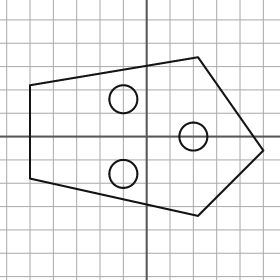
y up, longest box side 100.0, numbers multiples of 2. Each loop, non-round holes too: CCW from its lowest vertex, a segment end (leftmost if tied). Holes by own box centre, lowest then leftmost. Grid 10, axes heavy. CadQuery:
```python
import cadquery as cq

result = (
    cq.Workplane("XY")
    .moveTo(22.0, -34.0)
    .lineTo(50.0, -6.0)
    .lineTo(22.0, 34.0)
    .lineTo(-50.0, 22.0)
    .lineTo(-50.0, -18.0)
    .close()
    .moveTo(-10.0, -16.0)
    .circle(6.0)
    .moveTo(20.0, 0.0)
    .circle(6.0)
    .moveTo(-10.0, 16.0)
    .circle(6.0)
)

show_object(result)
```